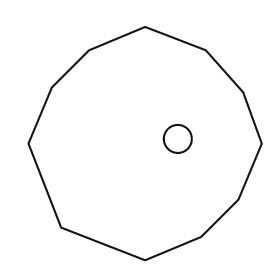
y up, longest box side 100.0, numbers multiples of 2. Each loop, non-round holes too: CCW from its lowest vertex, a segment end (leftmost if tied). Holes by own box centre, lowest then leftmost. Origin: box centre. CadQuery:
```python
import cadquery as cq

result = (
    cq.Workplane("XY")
    .moveTo(0.0, -50.0)
    .lineTo(24.0, -40.0)
    .lineTo(40.0, -24.0)
    .lineTo(50.0, 0.0)
    .lineTo(42.0, 22.0)
    .lineTo(26.0, 40.0)
    .lineTo(0.0, 50.0)
    .lineTo(-24.0, 40.0)
    .lineTo(-40.0, 24.0)
    .lineTo(-50.0, 0.0)
    .lineTo(-36.0, -36.0)
    .close()
    .moveTo(14.0, 2.0)
    .circle(6.0)
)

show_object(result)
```